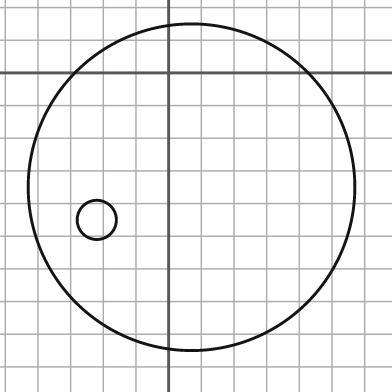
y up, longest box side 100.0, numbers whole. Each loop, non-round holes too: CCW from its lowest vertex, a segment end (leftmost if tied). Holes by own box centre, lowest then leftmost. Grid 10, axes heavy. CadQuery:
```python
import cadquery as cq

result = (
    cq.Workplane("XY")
    .moveTo(7.0, -35.0)
    .circle(50.0)
    .moveTo(-22.0, -45.0)
    .circle(6.0)
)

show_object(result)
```